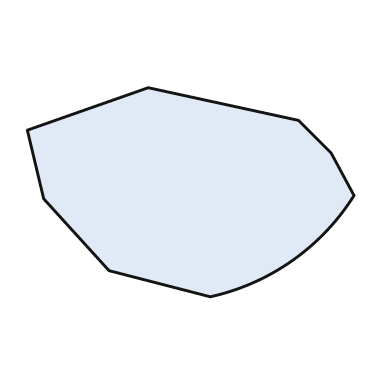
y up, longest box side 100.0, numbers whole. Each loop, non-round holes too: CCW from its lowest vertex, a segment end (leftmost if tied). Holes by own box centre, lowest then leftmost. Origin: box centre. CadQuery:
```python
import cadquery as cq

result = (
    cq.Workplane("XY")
    .moveTo(6.0, -32.0)
    .threePointArc((31.0, -21.0), (50.0, -1.0))
    .lineTo(43.0, 12.0)
    .lineTo(33.0, 22.0)
    .lineTo(-13.0, 32.0)
    .lineTo(-50.0, 19.0)
    .lineTo(-45.0, -2.0)
    .lineTo(-25.0, -24.0)
    .close()
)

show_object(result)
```